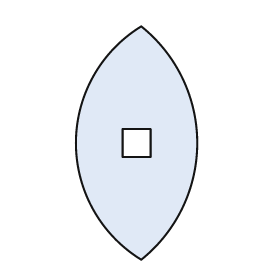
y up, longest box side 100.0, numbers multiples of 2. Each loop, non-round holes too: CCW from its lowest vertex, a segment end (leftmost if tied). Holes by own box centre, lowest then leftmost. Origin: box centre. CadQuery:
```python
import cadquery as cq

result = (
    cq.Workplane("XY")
    .moveTo(2.0, -50.0)
    .threePointArc((26.0, 0.0), (2.0, 50.0))
    .threePointArc((-26.0, 0.0), (2.0, -50.0))
    .close()
    .moveTo(-6.0, -6.0)
    .lineTo(6.0, -6.0)
    .lineTo(6.0, 6.0)
    .lineTo(-6.0, 6.0)
    .close()
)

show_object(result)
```